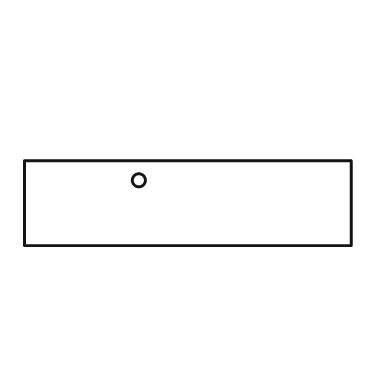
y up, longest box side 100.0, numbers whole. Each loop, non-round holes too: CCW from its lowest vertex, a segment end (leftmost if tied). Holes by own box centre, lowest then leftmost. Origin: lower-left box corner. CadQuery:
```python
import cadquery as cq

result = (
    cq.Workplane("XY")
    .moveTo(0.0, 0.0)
    .lineTo(100.0, 0.0)
    .lineTo(100.0, 26.0)
    .lineTo(0.0, 26.0)
    .close()
    .moveTo(35.0, 20.0)
    .circle(2.0)
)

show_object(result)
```